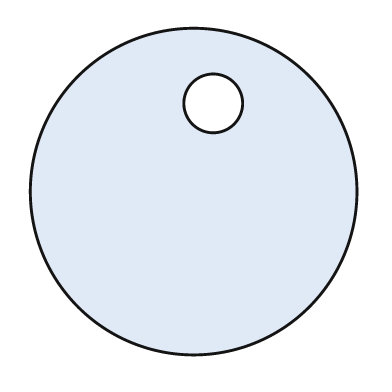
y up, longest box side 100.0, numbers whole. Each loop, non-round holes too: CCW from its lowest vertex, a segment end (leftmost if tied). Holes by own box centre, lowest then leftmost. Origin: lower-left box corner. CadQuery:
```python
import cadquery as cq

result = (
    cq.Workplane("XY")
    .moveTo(50.0, 50.0)
    .circle(50.0)
    .moveTo(56.0, 77.0)
    .circle(9.0)
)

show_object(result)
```